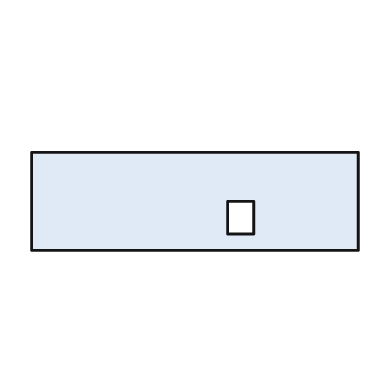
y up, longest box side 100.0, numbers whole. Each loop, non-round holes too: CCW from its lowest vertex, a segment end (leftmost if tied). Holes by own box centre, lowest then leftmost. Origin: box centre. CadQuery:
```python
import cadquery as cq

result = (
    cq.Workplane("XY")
    .moveTo(-50.0, -15.0)
    .lineTo(50.0, -15.0)
    .lineTo(50.0, 15.0)
    .lineTo(-50.0, 15.0)
    .close()
    .moveTo(10.0, -10.0)
    .lineTo(18.0, -10.0)
    .lineTo(18.0, 0.0)
    .lineTo(10.0, 0.0)
    .close()
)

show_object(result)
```